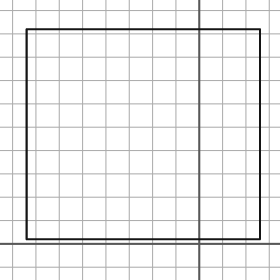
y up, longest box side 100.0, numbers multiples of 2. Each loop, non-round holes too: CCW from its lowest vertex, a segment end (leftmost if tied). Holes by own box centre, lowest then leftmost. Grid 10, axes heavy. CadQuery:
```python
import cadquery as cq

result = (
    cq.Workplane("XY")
    .moveTo(-74.0, 2.0)
    .lineTo(26.0, 2.0)
    .lineTo(26.0, 92.0)
    .lineTo(-74.0, 92.0)
    .close()
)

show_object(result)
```